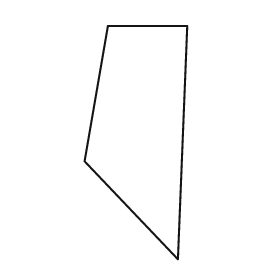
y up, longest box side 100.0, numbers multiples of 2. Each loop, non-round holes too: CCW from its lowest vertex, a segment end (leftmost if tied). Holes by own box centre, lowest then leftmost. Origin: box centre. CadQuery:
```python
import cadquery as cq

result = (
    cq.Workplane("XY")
    .moveTo(18.0, -50.0)
    .lineTo(22.0, 50.0)
    .lineTo(-12.0, 50.0)
    .lineTo(-22.0, -8.0)
    .close()
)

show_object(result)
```